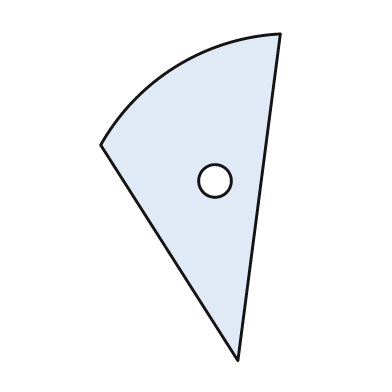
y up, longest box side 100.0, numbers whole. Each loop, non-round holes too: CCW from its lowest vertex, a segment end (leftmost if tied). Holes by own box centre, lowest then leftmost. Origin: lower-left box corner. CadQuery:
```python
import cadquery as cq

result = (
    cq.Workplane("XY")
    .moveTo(42.0, 0.0)
    .lineTo(55.0, 100.0)
    .threePointArc((23.0, 90.0), (0.0, 66.0))
    .close()
    .moveTo(35.0, 55.0)
    .circle(5.0)
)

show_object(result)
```